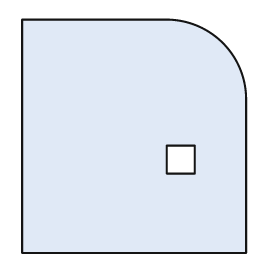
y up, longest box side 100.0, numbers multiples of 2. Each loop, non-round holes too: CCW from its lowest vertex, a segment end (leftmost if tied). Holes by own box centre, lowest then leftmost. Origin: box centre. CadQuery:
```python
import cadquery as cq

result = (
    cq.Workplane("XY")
    .moveTo(-48.0, -50.0)
    .lineTo(48.0, -50.0)
    .lineTo(48.0, 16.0)
    .threePointArc((38.0, 40.0), (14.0, 50.0))
    .lineTo(-48.0, 50.0)
    .close()
    .moveTo(14.0, -16.0)
    .lineTo(26.0, -16.0)
    .lineTo(26.0, -4.0)
    .lineTo(14.0, -4.0)
    .close()
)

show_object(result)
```